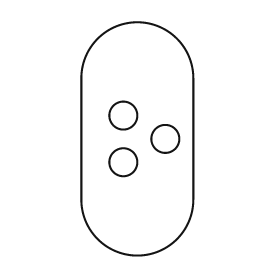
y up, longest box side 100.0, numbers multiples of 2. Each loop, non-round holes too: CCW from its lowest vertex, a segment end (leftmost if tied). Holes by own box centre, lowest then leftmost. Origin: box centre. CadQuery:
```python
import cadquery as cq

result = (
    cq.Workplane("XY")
    .moveTo(-24.0, -26.0)
    .threePointArc((0.0, -50.0), (24.0, -26.0))
    .lineTo(24.0, 26.0)
    .threePointArc((0.0, 50.0), (-24.0, 26.0))
    .close()
    .moveTo(-6.0, -10.0)
    .circle(6.0)
    .moveTo(12.0, 0.0)
    .circle(6.0)
    .moveTo(-6.0, 10.0)
    .circle(6.0)
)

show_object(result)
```